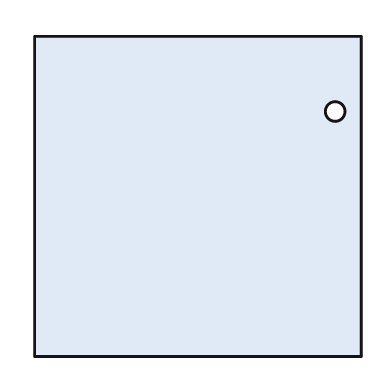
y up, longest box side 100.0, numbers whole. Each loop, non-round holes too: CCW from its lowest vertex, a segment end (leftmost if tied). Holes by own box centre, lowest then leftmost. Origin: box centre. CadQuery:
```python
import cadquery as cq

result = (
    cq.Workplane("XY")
    .moveTo(-50.0, -49.0)
    .lineTo(50.0, -49.0)
    .lineTo(50.0, 49.0)
    .lineTo(-50.0, 49.0)
    .close()
    .moveTo(42.0, 26.0)
    .circle(3.0)
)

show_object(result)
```